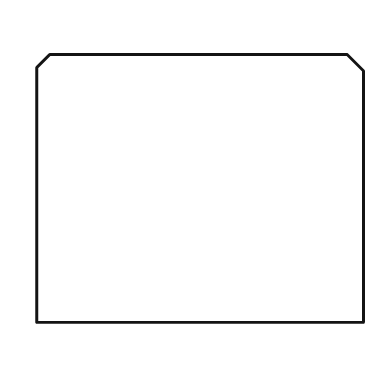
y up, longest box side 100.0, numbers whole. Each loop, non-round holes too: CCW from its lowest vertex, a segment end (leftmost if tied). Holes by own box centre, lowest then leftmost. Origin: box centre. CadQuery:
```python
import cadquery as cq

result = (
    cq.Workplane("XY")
    .moveTo(-50.0, -41.0)
    .lineTo(50.0, -41.0)
    .lineTo(50.0, 36.0)
    .lineTo(45.0, 41.0)
    .lineTo(-46.0, 41.0)
    .lineTo(-50.0, 37.0)
    .close()
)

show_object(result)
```